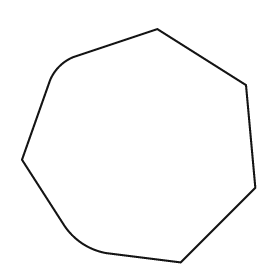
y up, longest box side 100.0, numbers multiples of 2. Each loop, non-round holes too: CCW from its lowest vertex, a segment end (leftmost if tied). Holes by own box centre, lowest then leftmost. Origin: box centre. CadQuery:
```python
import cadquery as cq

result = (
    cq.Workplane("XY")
    .moveTo(18.0, -50.0)
    .lineTo(50.0, -18.0)
    .lineTo(46.0, 26.0)
    .lineTo(8.0, 50.0)
    .lineTo(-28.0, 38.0)
    .threePointArc((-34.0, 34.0), (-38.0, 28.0))
    .lineTo(-50.0, -6.0)
    .lineTo(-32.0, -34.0)
    .threePointArc((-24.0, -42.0), (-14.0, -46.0))
    .close()
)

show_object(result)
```